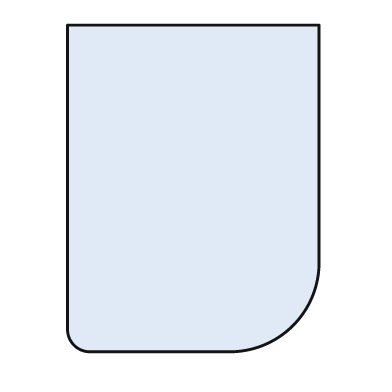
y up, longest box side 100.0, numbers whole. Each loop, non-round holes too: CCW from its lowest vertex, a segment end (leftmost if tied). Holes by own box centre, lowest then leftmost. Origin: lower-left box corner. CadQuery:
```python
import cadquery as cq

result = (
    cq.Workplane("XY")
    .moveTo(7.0, 0.0)
    .lineTo(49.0, 0.0)
    .threePointArc((69.0, 8.0), (77.0, 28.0))
    .lineTo(77.0, 100.0)
    .lineTo(0.0, 100.0)
    .lineTo(0.0, 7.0)
    .threePointArc((2.0, 2.0), (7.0, 0.0))
    .close()
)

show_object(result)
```